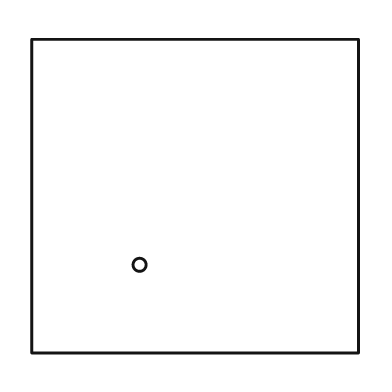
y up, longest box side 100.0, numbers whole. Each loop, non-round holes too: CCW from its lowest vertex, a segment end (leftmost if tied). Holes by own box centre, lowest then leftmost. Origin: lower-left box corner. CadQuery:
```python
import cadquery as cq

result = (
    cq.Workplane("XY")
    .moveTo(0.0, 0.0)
    .lineTo(100.0, 0.0)
    .lineTo(100.0, 96.0)
    .lineTo(0.0, 96.0)
    .close()
    .moveTo(33.0, 27.0)
    .circle(2.0)
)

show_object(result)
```